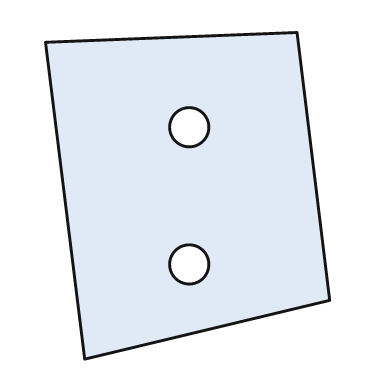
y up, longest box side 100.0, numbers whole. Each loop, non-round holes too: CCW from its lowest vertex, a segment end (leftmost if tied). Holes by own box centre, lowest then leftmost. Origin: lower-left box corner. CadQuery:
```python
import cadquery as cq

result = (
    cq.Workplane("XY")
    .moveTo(12.0, 0.0)
    .lineTo(87.0, 18.0)
    .lineTo(77.0, 100.0)
    .lineTo(0.0, 97.0)
    .close()
    .moveTo(44.0, 29.0)
    .circle(6.0)
    .moveTo(44.0, 71.0)
    .circle(6.0)
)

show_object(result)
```